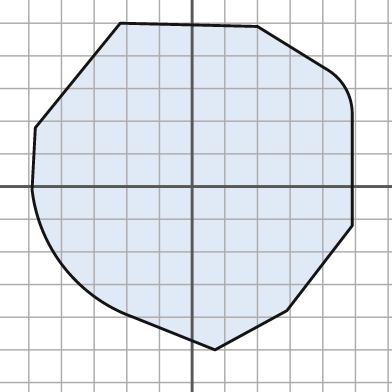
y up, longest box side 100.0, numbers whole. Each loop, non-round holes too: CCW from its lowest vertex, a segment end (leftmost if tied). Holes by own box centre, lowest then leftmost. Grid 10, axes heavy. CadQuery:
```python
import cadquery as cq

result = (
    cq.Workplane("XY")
    .moveTo(7.0, -50.0)
    .lineTo(29.0, -38.0)
    .lineTo(49.0, -12.0)
    .lineTo(49.0, 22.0)
    .threePointArc((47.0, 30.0), (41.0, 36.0))
    .lineTo(20.0, 49.0)
    .lineTo(-22.0, 50.0)
    .lineTo(-48.0, 18.0)
    .lineTo(-49.0, -1.0)
    .threePointArc((-39.0, -25.0), (-18.0, -40.0))
    .close()
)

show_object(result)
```